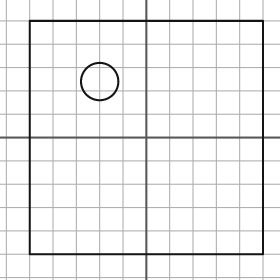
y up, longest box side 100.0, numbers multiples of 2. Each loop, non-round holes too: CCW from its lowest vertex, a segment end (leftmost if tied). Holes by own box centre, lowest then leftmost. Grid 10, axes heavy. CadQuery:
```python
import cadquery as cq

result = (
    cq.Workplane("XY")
    .moveTo(-50.0, -50.0)
    .lineTo(50.0, -50.0)
    .lineTo(50.0, 50.0)
    .lineTo(-50.0, 50.0)
    .close()
    .moveTo(-20.0, 24.0)
    .circle(8.0)
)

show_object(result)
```